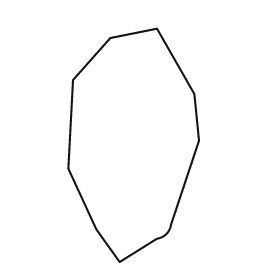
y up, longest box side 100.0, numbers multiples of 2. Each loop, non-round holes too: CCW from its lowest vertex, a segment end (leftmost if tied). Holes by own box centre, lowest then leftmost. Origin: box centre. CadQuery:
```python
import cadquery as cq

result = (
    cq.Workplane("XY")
    .moveTo(-6.0, -50.0)
    .lineTo(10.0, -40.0)
    .threePointArc((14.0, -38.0), (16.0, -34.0))
    .lineTo(28.0, 2.0)
    .lineTo(26.0, 22.0)
    .lineTo(10.0, 50.0)
    .lineTo(-10.0, 46.0)
    .lineTo(-26.0, 28.0)
    .lineTo(-28.0, -10.0)
    .lineTo(-16.0, -36.0)
    .close()
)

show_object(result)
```